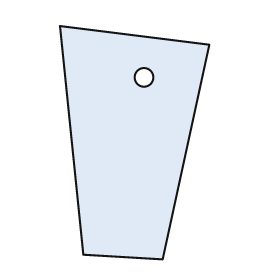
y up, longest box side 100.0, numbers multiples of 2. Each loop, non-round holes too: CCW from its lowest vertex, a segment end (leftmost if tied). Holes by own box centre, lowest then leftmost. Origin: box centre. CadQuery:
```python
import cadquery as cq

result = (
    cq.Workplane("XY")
    .moveTo(12.0, -50.0)
    .lineTo(32.0, 42.0)
    .lineTo(-32.0, 50.0)
    .lineTo(-22.0, -48.0)
    .close()
    .moveTo(4.0, 28.0)
    .circle(4.0)
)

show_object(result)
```